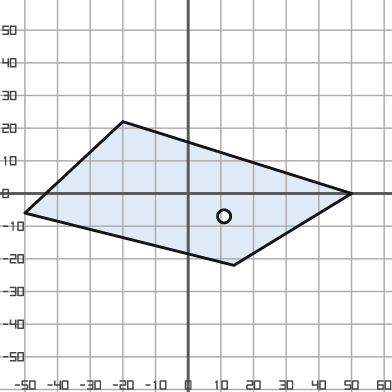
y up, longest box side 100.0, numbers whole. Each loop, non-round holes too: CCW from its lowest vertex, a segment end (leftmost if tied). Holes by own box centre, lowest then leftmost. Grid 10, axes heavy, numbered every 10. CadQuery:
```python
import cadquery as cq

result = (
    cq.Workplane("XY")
    .moveTo(14.0, -22.0)
    .lineTo(50.0, 0.0)
    .lineTo(-20.0, 22.0)
    .lineTo(-50.0, -6.0)
    .close()
    .moveTo(11.0, -7.0)
    .circle(2.0)
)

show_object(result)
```